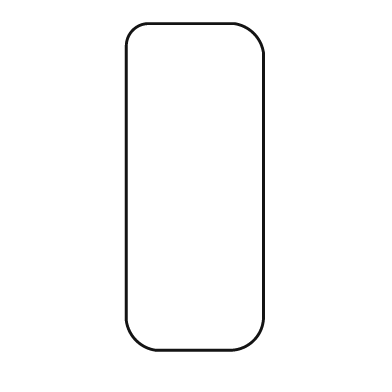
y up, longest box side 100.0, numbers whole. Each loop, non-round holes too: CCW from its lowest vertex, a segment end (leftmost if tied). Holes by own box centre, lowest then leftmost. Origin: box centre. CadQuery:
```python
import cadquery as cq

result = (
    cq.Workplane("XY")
    .moveTo(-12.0, -50.0)
    .lineTo(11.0, -50.0)
    .threePointArc((18.0, -47.0), (21.0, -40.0))
    .lineTo(21.0, 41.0)
    .threePointArc((18.0, 47.0), (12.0, 50.0))
    .lineTo(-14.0, 50.0)
    .threePointArc((-19.0, 48.0), (-21.0, 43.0))
    .lineTo(-21.0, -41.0)
    .threePointArc((-18.0, -47.0), (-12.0, -50.0))
    .close()
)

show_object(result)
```